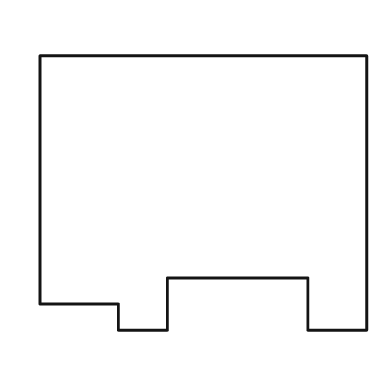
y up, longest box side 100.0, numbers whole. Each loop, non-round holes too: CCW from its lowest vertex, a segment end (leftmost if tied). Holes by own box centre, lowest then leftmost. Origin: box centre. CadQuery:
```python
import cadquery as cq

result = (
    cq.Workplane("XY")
    .moveTo(-26.0, -42.0)
    .lineTo(-11.0, -42.0)
    .lineTo(-11.0, -26.0)
    .lineTo(32.0, -26.0)
    .lineTo(32.0, -42.0)
    .lineTo(50.0, -42.0)
    .lineTo(50.0, 42.0)
    .lineTo(-50.0, 42.0)
    .lineTo(-50.0, -34.0)
    .lineTo(-26.0, -34.0)
    .close()
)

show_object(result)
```